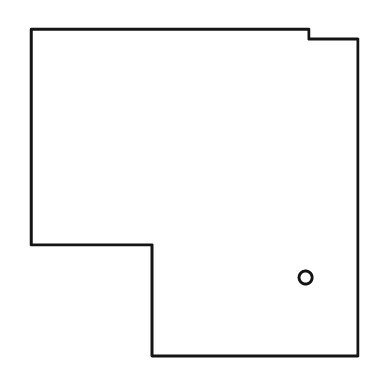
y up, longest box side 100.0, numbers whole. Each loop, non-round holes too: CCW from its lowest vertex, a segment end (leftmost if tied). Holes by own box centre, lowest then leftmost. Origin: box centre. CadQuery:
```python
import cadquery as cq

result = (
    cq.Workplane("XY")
    .moveTo(-13.0, -50.0)
    .lineTo(50.0, -50.0)
    .lineTo(50.0, 47.0)
    .lineTo(35.0, 47.0)
    .lineTo(35.0, 50.0)
    .lineTo(-50.0, 50.0)
    .lineTo(-50.0, -16.0)
    .lineTo(-13.0, -16.0)
    .close()
    .moveTo(34.0, -26.0)
    .circle(2.0)
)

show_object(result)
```